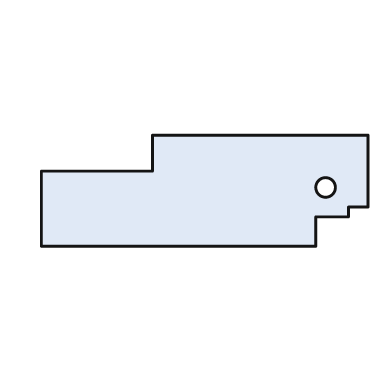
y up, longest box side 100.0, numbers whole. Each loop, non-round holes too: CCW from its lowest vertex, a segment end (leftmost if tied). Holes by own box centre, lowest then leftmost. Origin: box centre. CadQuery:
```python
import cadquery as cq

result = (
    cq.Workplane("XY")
    .moveTo(-50.0, -17.0)
    .lineTo(34.0, -17.0)
    .lineTo(34.0, -8.0)
    .lineTo(44.0, -8.0)
    .lineTo(44.0, -5.0)
    .lineTo(50.0, -5.0)
    .lineTo(50.0, 17.0)
    .lineTo(-16.0, 17.0)
    .lineTo(-16.0, 6.0)
    .lineTo(-50.0, 6.0)
    .close()
    .moveTo(37.0, 1.0)
    .circle(3.0)
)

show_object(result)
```